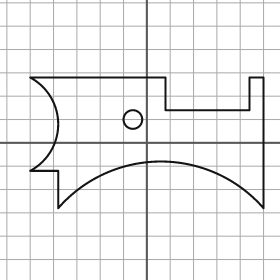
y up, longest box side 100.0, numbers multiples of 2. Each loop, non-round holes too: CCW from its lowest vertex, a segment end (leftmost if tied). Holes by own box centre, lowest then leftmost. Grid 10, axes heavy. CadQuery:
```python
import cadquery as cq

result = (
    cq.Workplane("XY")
    .moveTo(-38.0, -28.0)
    .threePointArc((6.0, -8.0), (50.0, -28.0))
    .lineTo(50.0, 28.0)
    .lineTo(44.0, 28.0)
    .lineTo(44.0, 14.0)
    .lineTo(8.0, 14.0)
    .lineTo(8.0, 28.0)
    .lineTo(-50.0, 28.0)
    .threePointArc((-38.0, 8.0), (-50.0, -12.0))
    .lineTo(-38.0, -12.0)
    .close()
    .moveTo(-6.0, 10.0)
    .circle(4.0)
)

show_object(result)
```